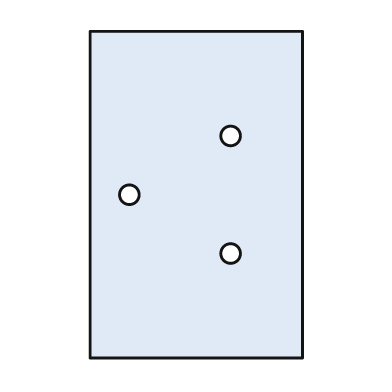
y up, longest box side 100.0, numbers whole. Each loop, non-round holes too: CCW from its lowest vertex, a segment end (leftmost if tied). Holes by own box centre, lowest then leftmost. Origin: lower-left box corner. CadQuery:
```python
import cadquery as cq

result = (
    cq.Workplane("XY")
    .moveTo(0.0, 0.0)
    .lineTo(65.0, 0.0)
    .lineTo(65.0, 100.0)
    .lineTo(0.0, 100.0)
    .close()
    .moveTo(43.0, 32.0)
    .circle(3.0)
    .moveTo(12.0, 50.0)
    .circle(3.0)
    .moveTo(43.0, 68.0)
    .circle(3.0)
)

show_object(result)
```